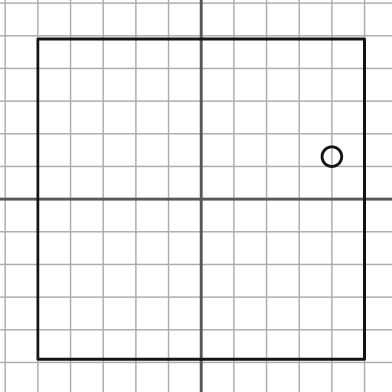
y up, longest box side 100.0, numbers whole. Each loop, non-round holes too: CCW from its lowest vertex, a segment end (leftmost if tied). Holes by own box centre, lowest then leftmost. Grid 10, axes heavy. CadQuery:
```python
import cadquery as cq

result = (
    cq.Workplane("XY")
    .moveTo(-50.0, -49.0)
    .lineTo(50.0, -49.0)
    .lineTo(50.0, 49.0)
    .lineTo(-50.0, 49.0)
    .close()
    .moveTo(40.0, 13.0)
    .circle(3.0)
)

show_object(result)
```